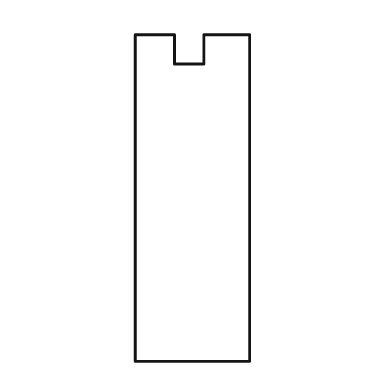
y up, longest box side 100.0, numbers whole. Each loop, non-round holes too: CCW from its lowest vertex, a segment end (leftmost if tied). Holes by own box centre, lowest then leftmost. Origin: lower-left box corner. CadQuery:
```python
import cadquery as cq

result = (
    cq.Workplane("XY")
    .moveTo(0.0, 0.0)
    .lineTo(35.0, 0.0)
    .lineTo(35.0, 100.0)
    .lineTo(21.0, 100.0)
    .lineTo(21.0, 91.0)
    .lineTo(12.0, 91.0)
    .lineTo(12.0, 100.0)
    .lineTo(0.0, 100.0)
    .close()
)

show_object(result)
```